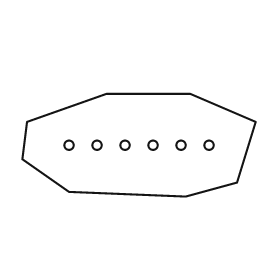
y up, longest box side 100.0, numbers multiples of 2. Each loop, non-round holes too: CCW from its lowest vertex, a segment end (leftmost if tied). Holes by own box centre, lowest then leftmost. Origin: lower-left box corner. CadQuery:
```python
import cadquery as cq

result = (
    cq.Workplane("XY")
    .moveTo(70.0, 0.0)
    .lineTo(92.0, 6.0)
    .lineTo(100.0, 32.0)
    .lineTo(72.0, 44.0)
    .lineTo(36.0, 44.0)
    .lineTo(2.0, 32.0)
    .lineTo(0.0, 16.0)
    .lineTo(20.0, 2.0)
    .close()
    .moveTo(20.0, 22.0)
    .circle(2.0)
    .moveTo(32.0, 22.0)
    .circle(2.0)
    .moveTo(44.0, 22.0)
    .circle(2.0)
    .moveTo(56.0, 22.0)
    .circle(2.0)
    .moveTo(68.0, 22.0)
    .circle(2.0)
    .moveTo(80.0, 22.0)
    .circle(2.0)
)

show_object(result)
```